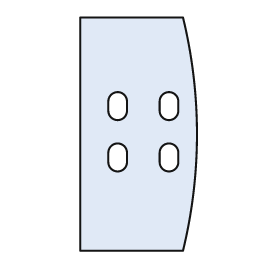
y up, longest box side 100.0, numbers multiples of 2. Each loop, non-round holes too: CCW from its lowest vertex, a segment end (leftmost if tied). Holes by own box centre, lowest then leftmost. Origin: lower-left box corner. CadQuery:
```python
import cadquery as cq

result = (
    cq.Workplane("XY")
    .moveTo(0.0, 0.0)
    .lineTo(44.0, 0.0)
    .threePointArc((50.0, 50.0), (44.0, 100.0))
    .lineTo(0.0, 100.0)
    .close()
    .moveTo(12.0, 38.0)
    .threePointArc((16.0, 34.0), (20.0, 38.0))
    .lineTo(20.0, 42.0)
    .threePointArc((16.0, 46.0), (12.0, 42.0))
    .close()
    .moveTo(34.0, 38.0)
    .threePointArc((38.0, 34.0), (42.0, 38.0))
    .lineTo(42.0, 42.0)
    .threePointArc((38.0, 46.0), (34.0, 42.0))
    .close()
    .moveTo(12.0, 60.0)
    .threePointArc((16.0, 56.0), (20.0, 60.0))
    .lineTo(20.0, 64.0)
    .threePointArc((16.0, 68.0), (12.0, 64.0))
    .close()
    .moveTo(34.0, 60.0)
    .threePointArc((38.0, 56.0), (42.0, 60.0))
    .lineTo(42.0, 64.0)
    .threePointArc((38.0, 68.0), (34.0, 64.0))
    .close()
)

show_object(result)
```